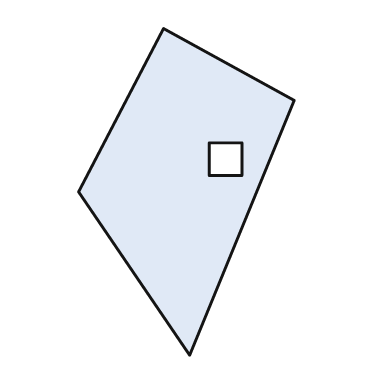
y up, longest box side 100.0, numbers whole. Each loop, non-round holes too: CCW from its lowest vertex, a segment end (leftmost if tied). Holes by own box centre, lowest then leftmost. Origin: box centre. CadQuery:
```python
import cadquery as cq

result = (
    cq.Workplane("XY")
    .moveTo(1.0, -50.0)
    .lineTo(33.0, 28.0)
    .lineTo(-7.0, 50.0)
    .lineTo(-33.0, 0.0)
    .close()
    .moveTo(7.0, 5.0)
    .lineTo(17.0, 5.0)
    .lineTo(17.0, 15.0)
    .lineTo(7.0, 15.0)
    .close()
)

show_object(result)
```